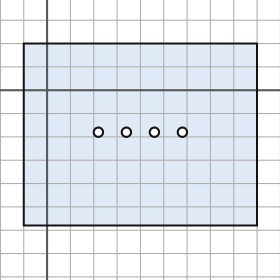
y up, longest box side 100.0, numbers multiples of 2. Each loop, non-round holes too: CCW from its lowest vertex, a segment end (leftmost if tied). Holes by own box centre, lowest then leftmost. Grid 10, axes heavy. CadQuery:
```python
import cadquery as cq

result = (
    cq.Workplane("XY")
    .moveTo(-10.0, -58.0)
    .lineTo(90.0, -58.0)
    .lineTo(90.0, 20.0)
    .lineTo(-10.0, 20.0)
    .close()
    .moveTo(22.0, -18.0)
    .circle(2.0)
    .moveTo(34.0, -18.0)
    .circle(2.0)
    .moveTo(46.0, -18.0)
    .circle(2.0)
    .moveTo(58.0, -18.0)
    .circle(2.0)
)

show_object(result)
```